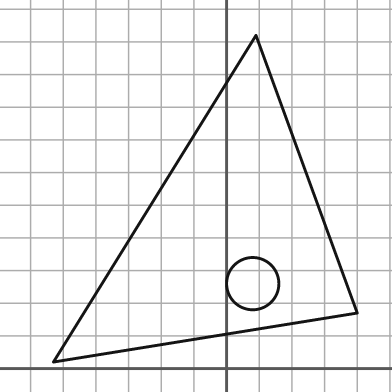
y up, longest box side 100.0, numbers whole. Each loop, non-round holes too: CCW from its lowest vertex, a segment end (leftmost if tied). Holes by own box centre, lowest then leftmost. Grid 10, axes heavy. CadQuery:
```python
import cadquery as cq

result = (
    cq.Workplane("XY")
    .moveTo(-53.0, 2.0)
    .lineTo(40.0, 17.0)
    .lineTo(9.0, 102.0)
    .close()
    .moveTo(8.0, 26.0)
    .circle(8.0)
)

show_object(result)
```